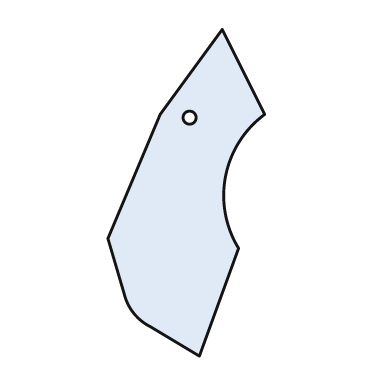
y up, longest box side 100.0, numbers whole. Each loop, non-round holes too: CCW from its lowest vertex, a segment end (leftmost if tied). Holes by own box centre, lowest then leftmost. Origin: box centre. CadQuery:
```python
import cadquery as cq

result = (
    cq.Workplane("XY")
    .moveTo(4.0, -50.0)
    .lineTo(16.0, -17.0)
    .threePointArc((12.0, 5.0), (24.0, 24.0))
    .lineTo(11.0, 50.0)
    .lineTo(-8.0, 24.0)
    .lineTo(-24.0, -14.0)
    .lineTo(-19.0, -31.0)
    .threePointArc((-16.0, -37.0), (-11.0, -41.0))
    .close()
    .moveTo(1.0, 23.0)
    .circle(2.0)
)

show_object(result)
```